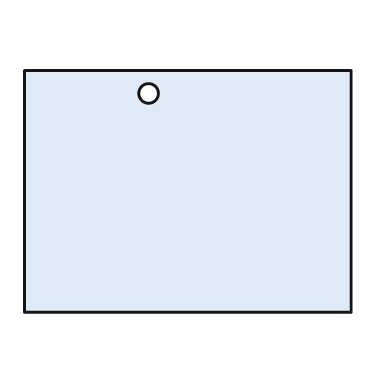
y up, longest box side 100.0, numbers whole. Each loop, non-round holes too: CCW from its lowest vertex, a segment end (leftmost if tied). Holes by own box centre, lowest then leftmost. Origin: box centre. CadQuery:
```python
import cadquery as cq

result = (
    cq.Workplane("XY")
    .moveTo(-50.0, -37.0)
    .lineTo(50.0, -37.0)
    .lineTo(50.0, 37.0)
    .lineTo(-50.0, 37.0)
    .close()
    .moveTo(-12.0, 30.0)
    .circle(3.0)
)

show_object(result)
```